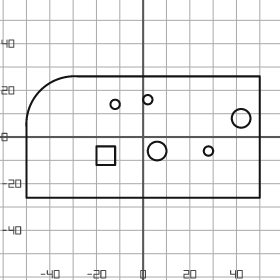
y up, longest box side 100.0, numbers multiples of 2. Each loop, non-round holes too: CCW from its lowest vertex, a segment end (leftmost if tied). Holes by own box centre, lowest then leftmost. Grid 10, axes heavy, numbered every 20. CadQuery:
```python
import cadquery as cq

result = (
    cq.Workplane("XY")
    .moveTo(-50.0, -26.0)
    .lineTo(50.0, -26.0)
    .lineTo(50.0, 26.0)
    .lineTo(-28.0, 26.0)
    .threePointArc((-44.0, 20.0), (-50.0, 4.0))
    .close()
    .moveTo(-20.0, -12.0)
    .lineTo(-12.0, -12.0)
    .lineTo(-12.0, -4.0)
    .lineTo(-20.0, -4.0)
    .close()
    .moveTo(6.0, -6.0)
    .circle(4.0)
    .moveTo(28.0, -6.0)
    .circle(2.0)
    .moveTo(42.0, 8.0)
    .circle(4.0)
    .moveTo(-12.0, 14.0)
    .circle(2.0)
    .moveTo(2.0, 16.0)
    .circle(2.0)
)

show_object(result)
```